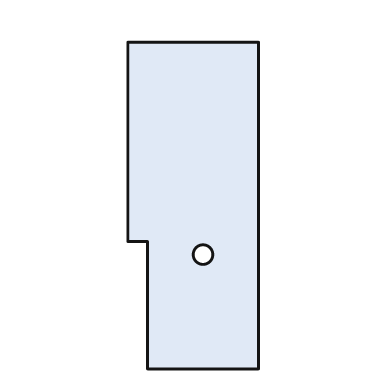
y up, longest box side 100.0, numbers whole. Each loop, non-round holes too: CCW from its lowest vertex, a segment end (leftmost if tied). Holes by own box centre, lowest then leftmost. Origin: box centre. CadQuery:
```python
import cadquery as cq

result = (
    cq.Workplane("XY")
    .moveTo(-14.0, -50.0)
    .lineTo(20.0, -50.0)
    .lineTo(20.0, 50.0)
    .lineTo(-20.0, 50.0)
    .lineTo(-20.0, -11.0)
    .lineTo(-14.0, -11.0)
    .close()
    .moveTo(3.0, -15.0)
    .circle(3.0)
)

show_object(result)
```